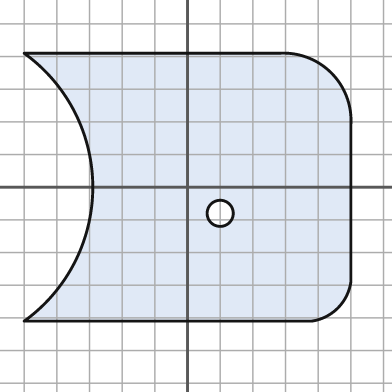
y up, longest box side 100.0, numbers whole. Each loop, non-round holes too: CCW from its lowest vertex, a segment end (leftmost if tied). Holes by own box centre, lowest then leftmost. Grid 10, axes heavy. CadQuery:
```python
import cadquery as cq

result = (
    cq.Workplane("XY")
    .moveTo(-50.0, -41.0)
    .lineTo(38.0, -41.0)
    .threePointArc((46.0, -37.0), (50.0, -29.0))
    .lineTo(50.0, 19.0)
    .threePointArc((44.0, 35.0), (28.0, 41.0))
    .lineTo(-50.0, 41.0)
    .threePointArc((-29.0, 0.0), (-50.0, -41.0))
    .close()
    .moveTo(10.0, -8.0)
    .circle(4.0)
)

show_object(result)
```